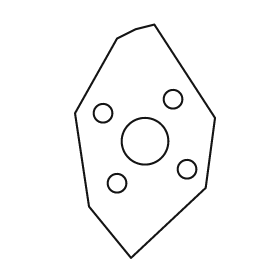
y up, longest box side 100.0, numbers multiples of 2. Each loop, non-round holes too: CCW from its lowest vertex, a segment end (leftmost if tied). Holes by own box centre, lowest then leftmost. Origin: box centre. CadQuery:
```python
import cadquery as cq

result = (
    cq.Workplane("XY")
    .moveTo(-6.0, -50.0)
    .lineTo(26.0, -20.0)
    .lineTo(30.0, 10.0)
    .lineTo(4.0, 50.0)
    .lineTo(-4.0, 48.0)
    .lineTo(-12.0, 44.0)
    .lineTo(-30.0, 12.0)
    .lineTo(-24.0, -28.0)
    .close()
    .moveTo(-12.0, -18.0)
    .circle(4.0)
    .moveTo(18.0, -12.0)
    .circle(4.0)
    .moveTo(0.0, 0.0)
    .circle(10.0)
    .moveTo(-18.0, 12.0)
    .circle(4.0)
    .moveTo(12.0, 18.0)
    .circle(4.0)
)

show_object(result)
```